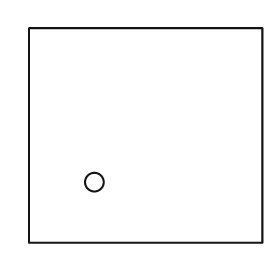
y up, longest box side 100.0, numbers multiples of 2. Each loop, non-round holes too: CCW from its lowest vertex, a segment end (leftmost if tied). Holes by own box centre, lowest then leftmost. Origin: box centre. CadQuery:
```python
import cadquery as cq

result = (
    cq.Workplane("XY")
    .moveTo(-50.0, -46.0)
    .lineTo(50.0, -46.0)
    .lineTo(50.0, 46.0)
    .lineTo(-50.0, 46.0)
    .close()
    .moveTo(-22.0, -20.0)
    .circle(4.0)
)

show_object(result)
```